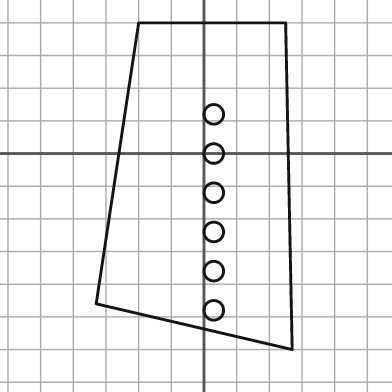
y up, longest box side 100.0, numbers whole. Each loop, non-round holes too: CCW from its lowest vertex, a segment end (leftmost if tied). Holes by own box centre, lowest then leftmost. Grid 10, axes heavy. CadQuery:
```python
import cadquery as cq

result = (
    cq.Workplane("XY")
    .moveTo(27.0, -60.0)
    .lineTo(25.0, 40.0)
    .lineTo(-20.0, 40.0)
    .lineTo(-33.0, -46.0)
    .close()
    .moveTo(3.0, -48.0)
    .circle(3.0)
    .moveTo(3.0, -36.0)
    .circle(3.0)
    .moveTo(3.0, -24.0)
    .circle(3.0)
    .moveTo(3.0, -12.0)
    .circle(3.0)
    .moveTo(3.0, 0.0)
    .circle(3.0)
    .moveTo(3.0, 12.0)
    .circle(3.0)
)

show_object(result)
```